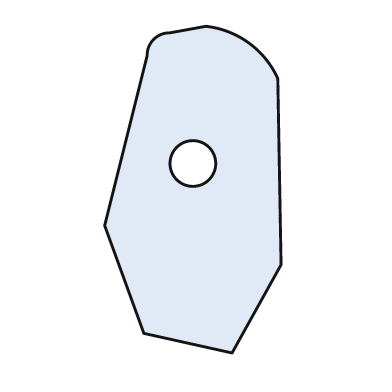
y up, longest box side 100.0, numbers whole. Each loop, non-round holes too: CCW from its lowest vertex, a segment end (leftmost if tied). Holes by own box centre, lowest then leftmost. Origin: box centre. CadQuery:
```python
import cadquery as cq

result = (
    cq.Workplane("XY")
    .moveTo(12.0, -50.0)
    .lineTo(27.0, -23.0)
    .lineTo(26.0, 34.0)
    .threePointArc((17.0, 45.0), (4.0, 50.0))
    .lineTo(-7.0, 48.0)
    .threePointArc((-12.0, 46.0), (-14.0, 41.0))
    .lineTo(-27.0, -11.0)
    .lineTo(-15.0, -44.0)
    .close()
    .moveTo(0.0, 8.0)
    .circle(7.0)
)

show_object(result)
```